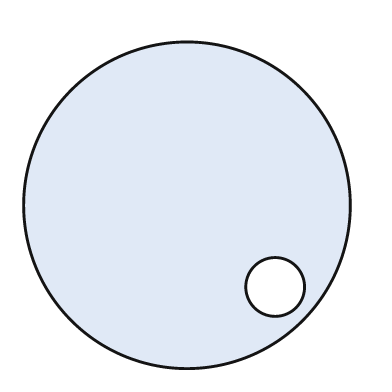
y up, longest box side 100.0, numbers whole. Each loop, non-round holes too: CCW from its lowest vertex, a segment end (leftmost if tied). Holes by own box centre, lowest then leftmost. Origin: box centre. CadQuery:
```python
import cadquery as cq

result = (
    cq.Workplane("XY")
    .moveTo(0.0, 0.0)
    .circle(50.0)
    .moveTo(27.0, -25.0)
    .circle(9.0)
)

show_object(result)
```